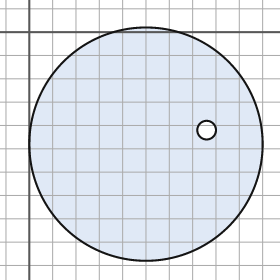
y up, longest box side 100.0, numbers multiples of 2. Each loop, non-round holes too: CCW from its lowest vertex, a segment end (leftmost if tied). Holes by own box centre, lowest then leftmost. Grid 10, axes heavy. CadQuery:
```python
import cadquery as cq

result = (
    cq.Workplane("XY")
    .moveTo(50.0, -48.0)
    .circle(50.0)
    .moveTo(76.0, -42.0)
    .circle(4.0)
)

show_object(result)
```